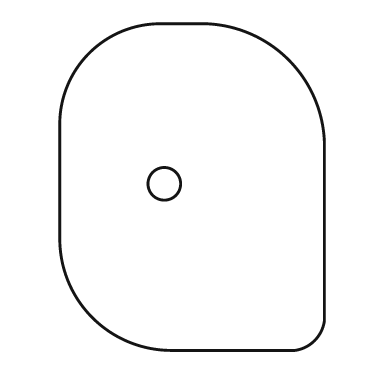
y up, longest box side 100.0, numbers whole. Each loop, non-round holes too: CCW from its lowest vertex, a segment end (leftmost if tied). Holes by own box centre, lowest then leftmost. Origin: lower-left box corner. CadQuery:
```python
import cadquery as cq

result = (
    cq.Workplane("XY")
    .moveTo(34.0, 0.0)
    .lineTo(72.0, 0.0)
    .threePointArc((78.0, 3.0), (81.0, 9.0))
    .lineTo(81.0, 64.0)
    .threePointArc((70.0, 89.0), (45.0, 100.0))
    .lineTo(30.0, 100.0)
    .threePointArc((9.0, 91.0), (0.0, 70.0))
    .lineTo(0.0, 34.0)
    .threePointArc((10.0, 10.0), (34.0, 0.0))
    .close()
    .moveTo(32.0, 51.0)
    .circle(5.0)
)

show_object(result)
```